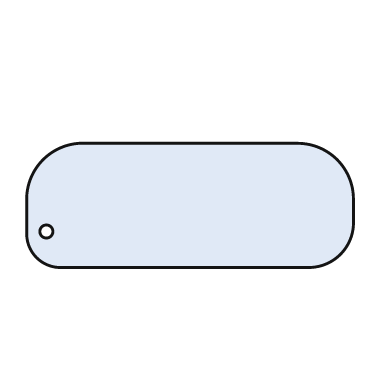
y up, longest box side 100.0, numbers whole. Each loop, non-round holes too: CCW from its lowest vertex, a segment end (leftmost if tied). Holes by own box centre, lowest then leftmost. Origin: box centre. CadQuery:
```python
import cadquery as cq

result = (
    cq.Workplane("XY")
    .moveTo(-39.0, -19.0)
    .lineTo(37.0, -19.0)
    .threePointArc((46.0, -15.0), (50.0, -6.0))
    .lineTo(50.0, 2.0)
    .threePointArc((45.0, 14.0), (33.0, 19.0))
    .lineTo(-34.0, 19.0)
    .threePointArc((-45.0, 14.0), (-50.0, 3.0))
    .lineTo(-50.0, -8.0)
    .threePointArc((-47.0, -16.0), (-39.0, -19.0))
    .close()
    .moveTo(-44.0, -8.0)
    .circle(2.0)
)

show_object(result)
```